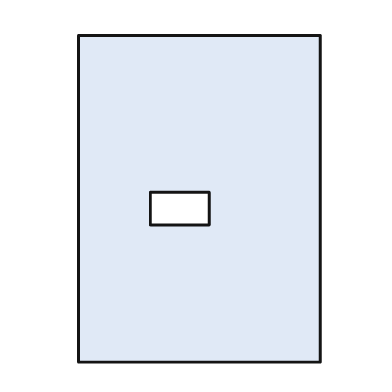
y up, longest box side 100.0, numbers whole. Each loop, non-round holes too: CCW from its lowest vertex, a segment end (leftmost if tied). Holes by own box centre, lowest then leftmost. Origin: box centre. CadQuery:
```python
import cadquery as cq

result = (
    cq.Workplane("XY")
    .moveTo(-37.0, -50.0)
    .lineTo(37.0, -50.0)
    .lineTo(37.0, 50.0)
    .lineTo(-37.0, 50.0)
    .close()
    .moveTo(-15.0, -8.0)
    .lineTo(3.0, -8.0)
    .lineTo(3.0, 2.0)
    .lineTo(-15.0, 2.0)
    .close()
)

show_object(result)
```